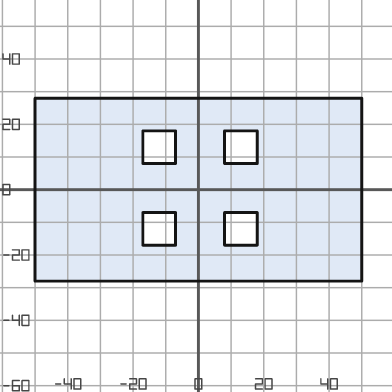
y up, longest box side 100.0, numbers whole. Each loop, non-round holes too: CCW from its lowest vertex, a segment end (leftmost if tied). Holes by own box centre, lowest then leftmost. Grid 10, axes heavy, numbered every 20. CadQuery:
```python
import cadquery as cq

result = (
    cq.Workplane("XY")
    .moveTo(-50.0, -28.0)
    .lineTo(50.0, -28.0)
    .lineTo(50.0, 28.0)
    .lineTo(-50.0, 28.0)
    .close()
    .moveTo(-17.0, -17.0)
    .lineTo(-7.0, -17.0)
    .lineTo(-7.0, -7.0)
    .lineTo(-17.0, -7.0)
    .close()
    .moveTo(8.0, -17.0)
    .lineTo(18.0, -17.0)
    .lineTo(18.0, -7.0)
    .lineTo(8.0, -7.0)
    .close()
    .moveTo(-17.0, 8.0)
    .lineTo(-7.0, 8.0)
    .lineTo(-7.0, 18.0)
    .lineTo(-17.0, 18.0)
    .close()
    .moveTo(8.0, 8.0)
    .lineTo(18.0, 8.0)
    .lineTo(18.0, 18.0)
    .lineTo(8.0, 18.0)
    .close()
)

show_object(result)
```